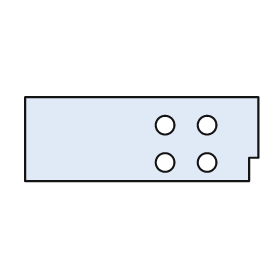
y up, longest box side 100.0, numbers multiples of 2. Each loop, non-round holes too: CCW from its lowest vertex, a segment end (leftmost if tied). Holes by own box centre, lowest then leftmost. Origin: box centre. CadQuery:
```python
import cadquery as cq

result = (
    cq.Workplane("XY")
    .moveTo(-50.0, -18.0)
    .lineTo(46.0, -18.0)
    .lineTo(46.0, -8.0)
    .lineTo(50.0, -8.0)
    .lineTo(50.0, 18.0)
    .lineTo(-50.0, 18.0)
    .close()
    .moveTo(10.0, -10.0)
    .circle(4.0)
    .moveTo(28.0, -10.0)
    .circle(4.0)
    .moveTo(10.0, 6.0)
    .circle(4.0)
    .moveTo(28.0, 6.0)
    .circle(4.0)
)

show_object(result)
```